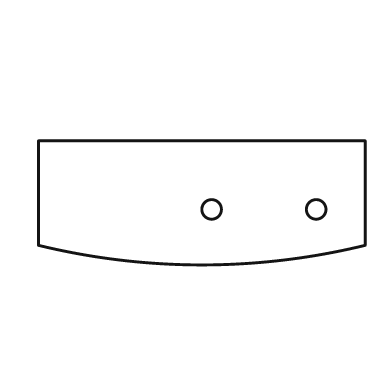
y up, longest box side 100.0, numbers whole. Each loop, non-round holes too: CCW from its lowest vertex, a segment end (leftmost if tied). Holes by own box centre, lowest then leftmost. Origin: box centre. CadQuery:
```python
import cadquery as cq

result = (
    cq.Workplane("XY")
    .moveTo(-50.0, -13.0)
    .threePointArc((0.0, -19.0), (50.0, -13.0))
    .lineTo(50.0, 19.0)
    .lineTo(-50.0, 19.0)
    .close()
    .moveTo(3.0, -2.0)
    .circle(3.0)
    .moveTo(35.0, -2.0)
    .circle(3.0)
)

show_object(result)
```